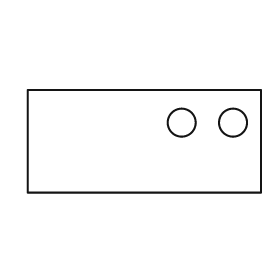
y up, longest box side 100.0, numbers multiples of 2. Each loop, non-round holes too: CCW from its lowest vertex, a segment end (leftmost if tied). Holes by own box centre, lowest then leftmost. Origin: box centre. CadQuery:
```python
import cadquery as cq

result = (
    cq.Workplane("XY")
    .moveTo(-50.0, -22.0)
    .lineTo(50.0, -22.0)
    .lineTo(50.0, 22.0)
    .lineTo(-50.0, 22.0)
    .close()
    .moveTo(16.0, 8.0)
    .circle(6.0)
    .moveTo(38.0, 8.0)
    .circle(6.0)
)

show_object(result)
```